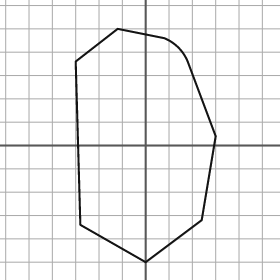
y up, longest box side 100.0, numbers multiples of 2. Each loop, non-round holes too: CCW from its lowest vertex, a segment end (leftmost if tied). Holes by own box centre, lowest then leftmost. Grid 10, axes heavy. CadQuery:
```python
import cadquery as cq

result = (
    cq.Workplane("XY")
    .moveTo(0.0, -50.0)
    .lineTo(24.0, -32.0)
    .lineTo(30.0, 4.0)
    .lineTo(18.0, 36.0)
    .threePointArc((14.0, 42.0), (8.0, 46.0))
    .lineTo(-12.0, 50.0)
    .lineTo(-30.0, 36.0)
    .lineTo(-28.0, -34.0)
    .close()
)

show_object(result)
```